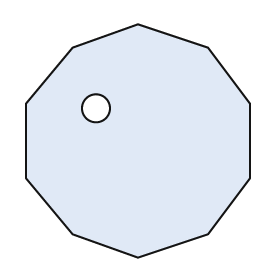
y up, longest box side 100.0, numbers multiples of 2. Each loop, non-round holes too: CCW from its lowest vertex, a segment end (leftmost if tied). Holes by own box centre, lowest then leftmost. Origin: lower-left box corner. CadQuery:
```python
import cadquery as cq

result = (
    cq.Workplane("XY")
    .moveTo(48.0, 0.0)
    .lineTo(78.0, 10.0)
    .lineTo(96.0, 34.0)
    .lineTo(96.0, 66.0)
    .lineTo(78.0, 90.0)
    .lineTo(48.0, 100.0)
    .lineTo(20.0, 90.0)
    .lineTo(0.0, 66.0)
    .lineTo(0.0, 34.0)
    .lineTo(20.0, 10.0)
    .close()
    .moveTo(30.0, 64.0)
    .circle(6.0)
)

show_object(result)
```